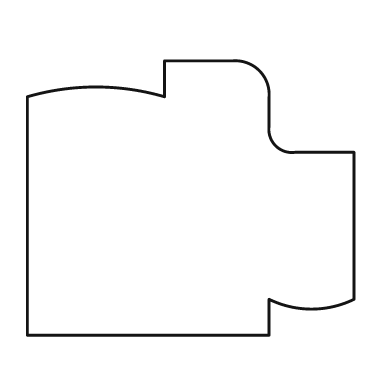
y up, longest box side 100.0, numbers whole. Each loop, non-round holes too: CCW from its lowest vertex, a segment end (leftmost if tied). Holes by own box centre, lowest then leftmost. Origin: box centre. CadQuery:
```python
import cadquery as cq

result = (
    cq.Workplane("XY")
    .moveTo(-50.0, -42.0)
    .lineTo(24.0, -42.0)
    .lineTo(24.0, -31.0)
    .threePointArc((37.0, -34.0), (50.0, -31.0))
    .lineTo(50.0, 14.0)
    .lineTo(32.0, 14.0)
    .threePointArc((26.0, 16.0), (24.0, 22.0))
    .lineTo(24.0, 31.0)
    .threePointArc((21.0, 39.0), (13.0, 42.0))
    .lineTo(-8.0, 42.0)
    .lineTo(-8.0, 31.0)
    .threePointArc((-29.0, 34.0), (-50.0, 31.0))
    .close()
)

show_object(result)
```